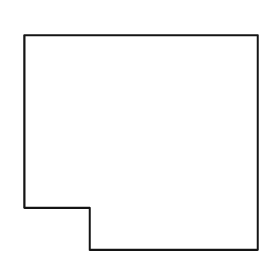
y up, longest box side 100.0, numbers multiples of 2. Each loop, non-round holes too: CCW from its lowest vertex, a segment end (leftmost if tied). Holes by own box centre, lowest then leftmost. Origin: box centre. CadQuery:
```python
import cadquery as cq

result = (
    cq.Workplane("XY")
    .moveTo(-22.0, -46.0)
    .lineTo(50.0, -46.0)
    .lineTo(50.0, 46.0)
    .lineTo(-50.0, 46.0)
    .lineTo(-50.0, -28.0)
    .lineTo(-22.0, -28.0)
    .close()
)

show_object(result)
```